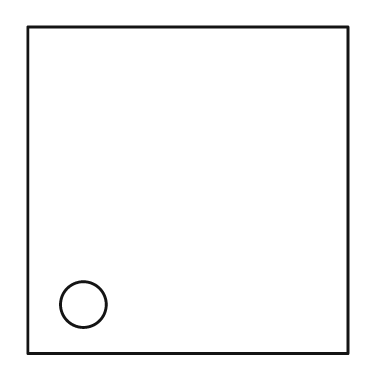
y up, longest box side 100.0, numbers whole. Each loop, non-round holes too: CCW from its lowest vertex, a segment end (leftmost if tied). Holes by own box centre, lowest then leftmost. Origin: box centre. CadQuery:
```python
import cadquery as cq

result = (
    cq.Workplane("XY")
    .moveTo(-49.0, -50.0)
    .lineTo(49.0, -50.0)
    .lineTo(49.0, 50.0)
    .lineTo(-49.0, 50.0)
    .close()
    .moveTo(-32.0, -35.0)
    .circle(7.0)
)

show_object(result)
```